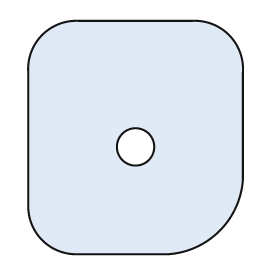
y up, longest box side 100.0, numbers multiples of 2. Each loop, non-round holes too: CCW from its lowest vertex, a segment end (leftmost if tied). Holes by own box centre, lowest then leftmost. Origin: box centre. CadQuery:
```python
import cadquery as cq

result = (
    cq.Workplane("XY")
    .moveTo(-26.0, -50.0)
    .lineTo(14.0, -50.0)
    .threePointArc((36.0, -40.0), (46.0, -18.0))
    .lineTo(46.0, 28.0)
    .threePointArc((40.0, 44.0), (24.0, 50.0))
    .lineTo(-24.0, 50.0)
    .threePointArc((-40.0, 44.0), (-46.0, 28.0))
    .lineTo(-46.0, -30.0)
    .threePointArc((-40.0, -44.0), (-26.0, -50.0))
    .close()
    .moveTo(0.0, -4.0)
    .circle(8.0)
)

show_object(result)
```